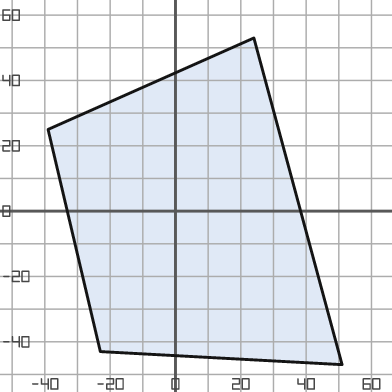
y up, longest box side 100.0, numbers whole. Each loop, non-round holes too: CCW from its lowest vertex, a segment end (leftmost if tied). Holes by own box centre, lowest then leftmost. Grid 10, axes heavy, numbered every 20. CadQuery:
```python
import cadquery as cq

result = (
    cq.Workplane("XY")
    .moveTo(51.0, -47.0)
    .lineTo(24.0, 53.0)
    .lineTo(-39.0, 25.0)
    .lineTo(-23.0, -43.0)
    .close()
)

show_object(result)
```